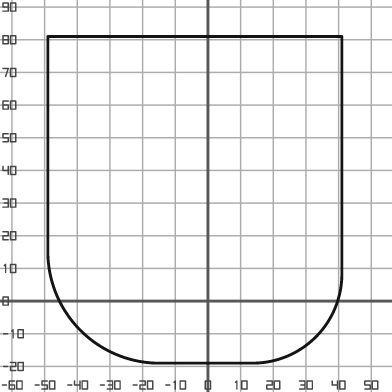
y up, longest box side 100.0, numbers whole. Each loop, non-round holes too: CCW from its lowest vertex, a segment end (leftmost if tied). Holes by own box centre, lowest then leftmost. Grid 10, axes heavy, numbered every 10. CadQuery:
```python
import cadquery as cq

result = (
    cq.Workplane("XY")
    .moveTo(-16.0, -19.0)
    .lineTo(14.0, -19.0)
    .threePointArc((33.0, -11.0), (41.0, 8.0))
    .lineTo(41.0, 81.0)
    .lineTo(-49.0, 81.0)
    .lineTo(-49.0, 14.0)
    .threePointArc((-39.0, -9.0), (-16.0, -19.0))
    .close()
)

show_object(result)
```